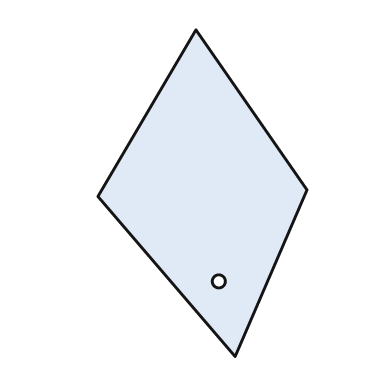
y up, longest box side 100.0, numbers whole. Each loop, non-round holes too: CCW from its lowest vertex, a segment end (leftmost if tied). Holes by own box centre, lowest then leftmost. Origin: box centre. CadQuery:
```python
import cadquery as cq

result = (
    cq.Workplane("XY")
    .moveTo(10.0, -50.0)
    .lineTo(32.0, 1.0)
    .lineTo(-2.0, 50.0)
    .lineTo(-32.0, -1.0)
    .close()
    .moveTo(5.0, -27.0)
    .circle(2.0)
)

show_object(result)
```